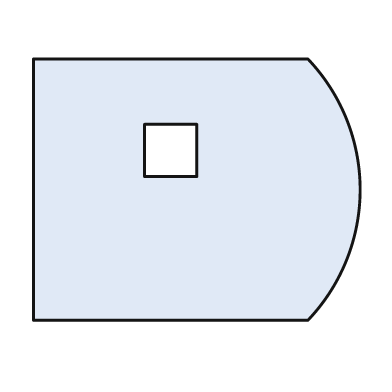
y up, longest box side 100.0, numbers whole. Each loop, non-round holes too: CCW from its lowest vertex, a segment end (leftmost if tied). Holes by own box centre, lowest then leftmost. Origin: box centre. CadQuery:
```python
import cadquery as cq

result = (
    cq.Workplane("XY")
    .moveTo(-50.0, -40.0)
    .lineTo(34.0, -40.0)
    .threePointArc((50.0, 0.0), (34.0, 40.0))
    .lineTo(-50.0, 40.0)
    .close()
    .moveTo(-16.0, 4.0)
    .lineTo(0.0, 4.0)
    .lineTo(0.0, 20.0)
    .lineTo(-16.0, 20.0)
    .close()
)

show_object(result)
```